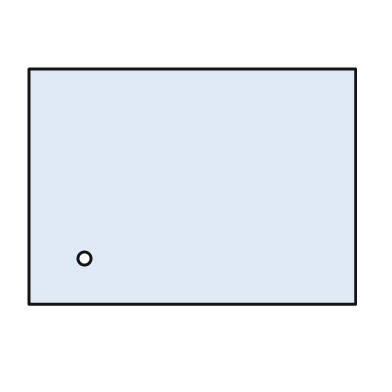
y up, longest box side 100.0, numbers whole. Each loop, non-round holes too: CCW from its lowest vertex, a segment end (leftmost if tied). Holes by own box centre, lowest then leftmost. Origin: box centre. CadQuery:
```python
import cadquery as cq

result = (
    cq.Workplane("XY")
    .moveTo(-50.0, -36.0)
    .lineTo(50.0, -36.0)
    .lineTo(50.0, 36.0)
    .lineTo(-50.0, 36.0)
    .close()
    .moveTo(-33.0, -22.0)
    .circle(2.0)
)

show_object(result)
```